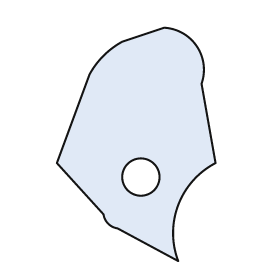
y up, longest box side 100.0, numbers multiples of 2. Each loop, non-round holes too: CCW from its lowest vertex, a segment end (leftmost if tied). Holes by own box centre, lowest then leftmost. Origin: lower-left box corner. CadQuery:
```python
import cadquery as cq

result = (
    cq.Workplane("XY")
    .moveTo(52.0, 0.0)
    .threePointArc((52.0, 24.0), (68.0, 42.0))
    .lineTo(62.0, 76.0)
    .threePointArc((60.0, 92.0), (46.0, 100.0))
    .lineTo(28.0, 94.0)
    .threePointArc((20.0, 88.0), (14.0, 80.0))
    .lineTo(0.0, 42.0)
    .lineTo(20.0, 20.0)
    .threePointArc((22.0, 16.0), (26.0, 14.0))
    .close()
    .moveTo(36.0, 36.0)
    .circle(8.0)
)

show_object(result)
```